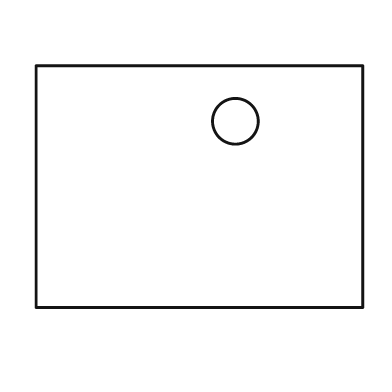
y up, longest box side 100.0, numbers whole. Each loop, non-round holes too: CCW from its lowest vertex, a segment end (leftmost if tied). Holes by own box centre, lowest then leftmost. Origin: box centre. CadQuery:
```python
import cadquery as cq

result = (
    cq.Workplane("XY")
    .moveTo(-50.0, -37.0)
    .lineTo(50.0, -37.0)
    .lineTo(50.0, 37.0)
    .lineTo(-50.0, 37.0)
    .close()
    .moveTo(11.0, 20.0)
    .circle(7.0)
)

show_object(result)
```